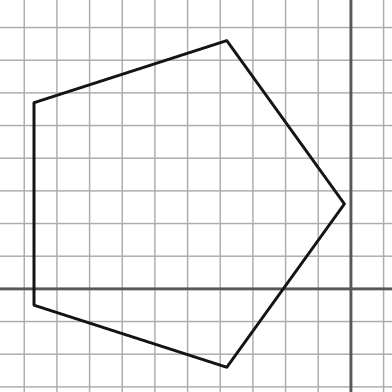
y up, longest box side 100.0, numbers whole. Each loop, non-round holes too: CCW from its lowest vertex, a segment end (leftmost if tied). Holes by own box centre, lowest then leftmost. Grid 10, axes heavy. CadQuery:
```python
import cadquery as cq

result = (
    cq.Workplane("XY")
    .moveTo(-38.0, -24.0)
    .lineTo(-2.0, 26.0)
    .lineTo(-38.0, 76.0)
    .lineTo(-97.0, 57.0)
    .lineTo(-97.0, -5.0)
    .close()
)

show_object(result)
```